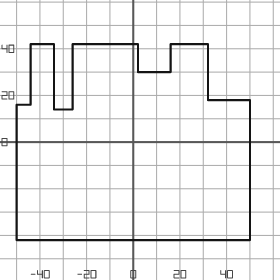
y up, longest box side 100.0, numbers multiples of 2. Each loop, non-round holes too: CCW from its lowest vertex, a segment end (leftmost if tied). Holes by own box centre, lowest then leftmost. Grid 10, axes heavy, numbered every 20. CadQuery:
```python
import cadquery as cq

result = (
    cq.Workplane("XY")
    .moveTo(-50.0, -42.0)
    .lineTo(50.0, -42.0)
    .lineTo(50.0, 18.0)
    .lineTo(32.0, 18.0)
    .lineTo(32.0, 42.0)
    .lineTo(16.0, 42.0)
    .lineTo(16.0, 30.0)
    .lineTo(2.0, 30.0)
    .lineTo(2.0, 42.0)
    .lineTo(-26.0, 42.0)
    .lineTo(-26.0, 14.0)
    .lineTo(-34.0, 14.0)
    .lineTo(-34.0, 42.0)
    .lineTo(-44.0, 42.0)
    .lineTo(-44.0, 16.0)
    .lineTo(-50.0, 16.0)
    .close()
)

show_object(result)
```